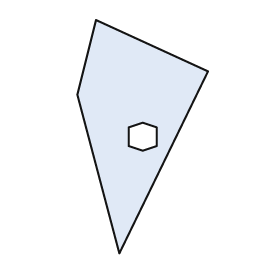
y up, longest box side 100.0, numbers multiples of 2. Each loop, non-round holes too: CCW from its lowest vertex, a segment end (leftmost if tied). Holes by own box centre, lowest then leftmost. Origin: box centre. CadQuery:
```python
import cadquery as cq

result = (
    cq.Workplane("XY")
    .moveTo(-10.0, -50.0)
    .lineTo(28.0, 28.0)
    .lineTo(-20.0, 50.0)
    .lineTo(-28.0, 18.0)
    .close()
    .moveTo(0.0, -6.0)
    .lineTo(6.0, -4.0)
    .lineTo(6.0, 4.0)
    .lineTo(0.0, 6.0)
    .lineTo(-6.0, 4.0)
    .lineTo(-6.0, -4.0)
    .close()
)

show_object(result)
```